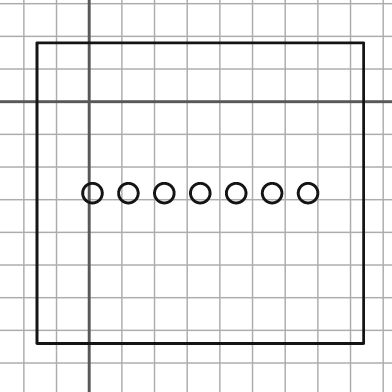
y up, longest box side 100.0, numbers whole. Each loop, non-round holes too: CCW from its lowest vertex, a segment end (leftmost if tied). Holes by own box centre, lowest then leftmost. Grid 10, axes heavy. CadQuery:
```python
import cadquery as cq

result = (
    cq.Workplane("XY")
    .moveTo(-16.0, -74.0)
    .lineTo(84.0, -74.0)
    .lineTo(84.0, 18.0)
    .lineTo(-16.0, 18.0)
    .close()
    .moveTo(1.0, -28.0)
    .circle(3.0)
    .moveTo(12.0, -28.0)
    .circle(3.0)
    .moveTo(23.0, -28.0)
    .circle(3.0)
    .moveTo(34.0, -28.0)
    .circle(3.0)
    .moveTo(45.0, -28.0)
    .circle(3.0)
    .moveTo(56.0, -28.0)
    .circle(3.0)
    .moveTo(67.0, -28.0)
    .circle(3.0)
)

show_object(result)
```